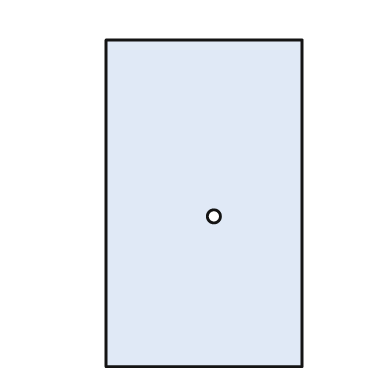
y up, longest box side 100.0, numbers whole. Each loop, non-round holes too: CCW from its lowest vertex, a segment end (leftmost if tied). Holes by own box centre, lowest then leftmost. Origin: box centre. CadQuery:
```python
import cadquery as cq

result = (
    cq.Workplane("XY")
    .moveTo(-30.0, -50.0)
    .lineTo(30.0, -50.0)
    .lineTo(30.0, 50.0)
    .lineTo(-30.0, 50.0)
    .close()
    .moveTo(3.0, -4.0)
    .circle(2.0)
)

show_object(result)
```